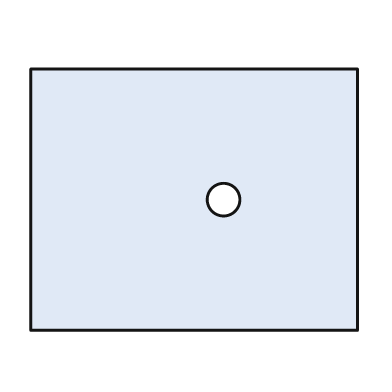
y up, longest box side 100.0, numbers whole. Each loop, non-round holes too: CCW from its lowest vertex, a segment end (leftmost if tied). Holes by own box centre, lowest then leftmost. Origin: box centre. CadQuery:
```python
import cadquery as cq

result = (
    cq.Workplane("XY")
    .moveTo(-50.0, -40.0)
    .lineTo(50.0, -40.0)
    .lineTo(50.0, 40.0)
    .lineTo(-50.0, 40.0)
    .close()
    .moveTo(9.0, 0.0)
    .circle(5.0)
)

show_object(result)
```